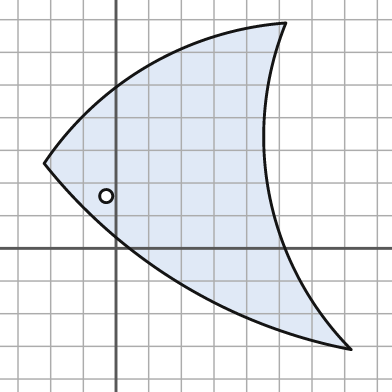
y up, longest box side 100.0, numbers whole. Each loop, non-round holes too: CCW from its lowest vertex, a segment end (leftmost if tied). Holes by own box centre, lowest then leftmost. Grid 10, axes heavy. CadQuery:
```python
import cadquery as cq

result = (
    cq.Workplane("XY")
    .moveTo(72.0, -31.0)
    .threePointArc((47.0, 16.0), (52.0, 69.0))
    .threePointArc((10.0, 56.0), (-22.0, 26.0))
    .threePointArc((20.0, -11.0), (72.0, -31.0))
    .close()
    .moveTo(-3.0, 16.0)
    .circle(2.0)
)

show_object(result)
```